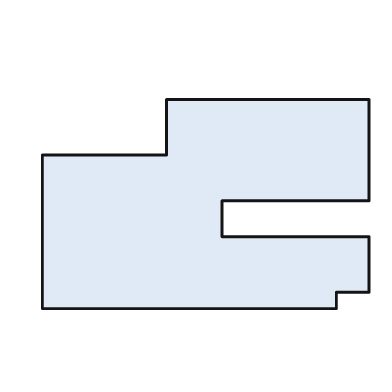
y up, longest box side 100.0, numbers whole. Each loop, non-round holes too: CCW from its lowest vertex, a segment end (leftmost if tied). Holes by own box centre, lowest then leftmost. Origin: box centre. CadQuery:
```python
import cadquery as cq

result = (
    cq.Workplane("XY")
    .moveTo(-50.0, -32.0)
    .lineTo(40.0, -32.0)
    .lineTo(40.0, -27.0)
    .lineTo(50.0, -27.0)
    .lineTo(50.0, -10.0)
    .lineTo(5.0, -10.0)
    .lineTo(5.0, 1.0)
    .lineTo(50.0, 1.0)
    .lineTo(50.0, 32.0)
    .lineTo(-12.0, 32.0)
    .lineTo(-12.0, 15.0)
    .lineTo(-50.0, 15.0)
    .close()
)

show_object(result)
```